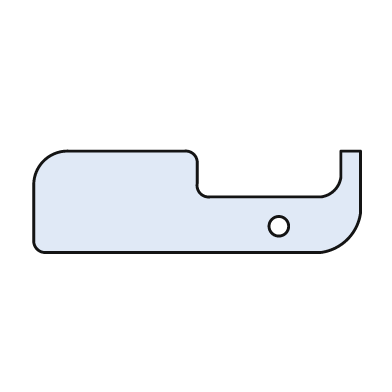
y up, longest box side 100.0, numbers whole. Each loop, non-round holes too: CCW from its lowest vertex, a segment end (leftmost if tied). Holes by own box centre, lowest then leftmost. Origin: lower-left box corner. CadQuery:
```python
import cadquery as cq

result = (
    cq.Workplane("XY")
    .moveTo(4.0, 0.0)
    .lineTo(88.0, 0.0)
    .threePointArc((96.0, 4.0), (100.0, 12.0))
    .lineTo(100.0, 31.0)
    .lineTo(94.0, 31.0)
    .lineTo(94.0, 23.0)
    .threePointArc((92.0, 19.0), (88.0, 17.0))
    .lineTo(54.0, 17.0)
    .threePointArc((51.0, 18.0), (50.0, 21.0))
    .lineTo(50.0, 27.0)
    .threePointArc((49.0, 30.0), (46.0, 31.0))
    .lineTo(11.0, 31.0)
    .threePointArc((3.0, 28.0), (0.0, 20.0))
    .lineTo(0.0, 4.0)
    .threePointArc((1.0, 1.0), (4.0, 0.0))
    .close()
    .moveTo(75.0, 8.0)
    .circle(3.0)
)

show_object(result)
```